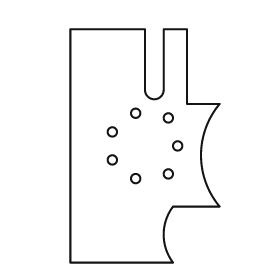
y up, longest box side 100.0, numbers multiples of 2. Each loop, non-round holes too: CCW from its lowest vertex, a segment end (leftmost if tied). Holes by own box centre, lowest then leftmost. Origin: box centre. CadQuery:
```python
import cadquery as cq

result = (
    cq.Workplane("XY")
    .moveTo(-32.0, -50.0)
    .lineTo(12.0, -50.0)
    .threePointArc((8.0, -38.0), (12.0, -26.0))
    .lineTo(32.0, -26.0)
    .threePointArc((24.0, -4.0), (32.0, 18.0))
    .lineTo(18.0, 18.0)
    .lineTo(18.0, 50.0)
    .lineTo(8.0, 50.0)
    .lineTo(8.0, 24.0)
    .threePointArc((4.0, 20.0), (0.0, 24.0))
    .lineTo(0.0, 50.0)
    .lineTo(-32.0, 50.0)
    .close()
    .moveTo(-4.0, -14.0)
    .circle(2.0)
    .moveTo(10.0, -12.0)
    .circle(2.0)
    .moveTo(-14.0, -6.0)
    .circle(2.0)
    .moveTo(14.0, 0.0)
    .circle(2.0)
    .moveTo(-14.0, 6.0)
    .circle(2.0)
    .moveTo(10.0, 12.0)
    .circle(2.0)
    .moveTo(-4.0, 14.0)
    .circle(2.0)
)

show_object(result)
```